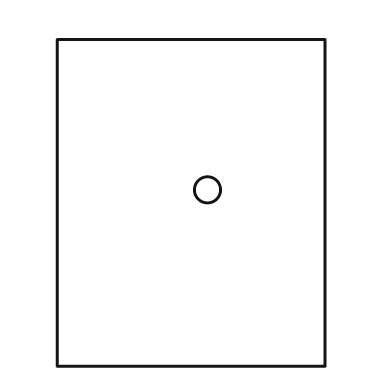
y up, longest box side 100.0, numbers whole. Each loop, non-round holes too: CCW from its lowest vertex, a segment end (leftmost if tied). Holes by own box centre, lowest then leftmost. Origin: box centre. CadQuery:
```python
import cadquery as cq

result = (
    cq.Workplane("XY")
    .moveTo(-41.0, -50.0)
    .lineTo(41.0, -50.0)
    .lineTo(41.0, 50.0)
    .lineTo(-41.0, 50.0)
    .close()
    .moveTo(5.0, 4.0)
    .circle(4.0)
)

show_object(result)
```